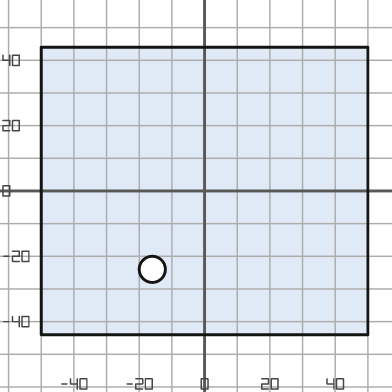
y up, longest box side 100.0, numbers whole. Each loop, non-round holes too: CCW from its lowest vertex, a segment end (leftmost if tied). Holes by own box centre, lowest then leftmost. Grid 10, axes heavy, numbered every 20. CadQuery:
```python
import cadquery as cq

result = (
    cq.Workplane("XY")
    .moveTo(-50.0, -44.0)
    .lineTo(50.0, -44.0)
    .lineTo(50.0, 44.0)
    .lineTo(-50.0, 44.0)
    .close()
    .moveTo(-16.0, -24.0)
    .circle(4.0)
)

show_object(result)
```